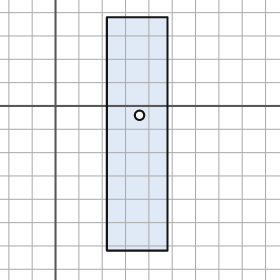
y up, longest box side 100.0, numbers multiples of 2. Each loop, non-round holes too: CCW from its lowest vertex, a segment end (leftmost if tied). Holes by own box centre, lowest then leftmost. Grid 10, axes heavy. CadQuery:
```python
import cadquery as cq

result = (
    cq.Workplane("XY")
    .moveTo(22.0, -62.0)
    .lineTo(48.0, -62.0)
    .lineTo(48.0, 38.0)
    .lineTo(22.0, 38.0)
    .close()
    .moveTo(36.0, -4.0)
    .circle(2.0)
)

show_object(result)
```